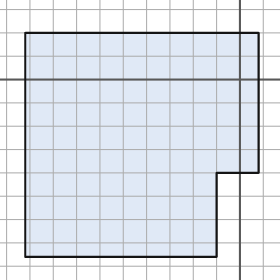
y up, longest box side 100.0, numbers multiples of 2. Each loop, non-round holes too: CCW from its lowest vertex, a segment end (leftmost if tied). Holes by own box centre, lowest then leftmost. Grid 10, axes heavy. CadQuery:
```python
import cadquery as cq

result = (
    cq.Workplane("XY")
    .moveTo(-92.0, -76.0)
    .lineTo(-10.0, -76.0)
    .lineTo(-10.0, -40.0)
    .lineTo(8.0, -40.0)
    .lineTo(8.0, 20.0)
    .lineTo(-92.0, 20.0)
    .close()
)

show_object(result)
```